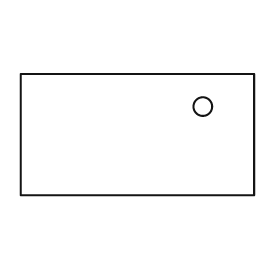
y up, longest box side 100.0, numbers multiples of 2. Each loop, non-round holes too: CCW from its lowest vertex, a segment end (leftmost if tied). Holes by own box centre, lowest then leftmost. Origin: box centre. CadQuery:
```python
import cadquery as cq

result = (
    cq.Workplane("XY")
    .moveTo(-50.0, -26.0)
    .lineTo(50.0, -26.0)
    .lineTo(50.0, 26.0)
    .lineTo(-50.0, 26.0)
    .close()
    .moveTo(28.0, 12.0)
    .circle(4.0)
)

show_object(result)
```